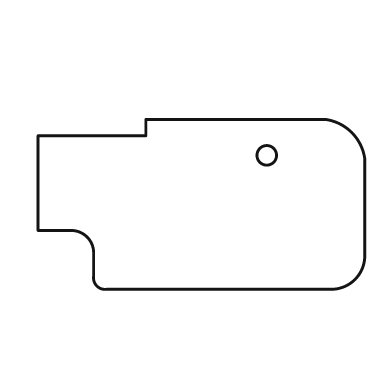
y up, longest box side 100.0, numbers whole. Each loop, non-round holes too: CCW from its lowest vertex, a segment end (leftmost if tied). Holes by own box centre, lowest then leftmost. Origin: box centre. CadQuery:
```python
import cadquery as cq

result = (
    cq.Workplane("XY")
    .moveTo(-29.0, -26.0)
    .lineTo(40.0, -26.0)
    .threePointArc((47.0, -23.0), (50.0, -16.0))
    .lineTo(50.0, 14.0)
    .threePointArc((46.0, 22.0), (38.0, 26.0))
    .lineTo(-17.0, 26.0)
    .lineTo(-17.0, 21.0)
    .lineTo(-50.0, 21.0)
    .lineTo(-50.0, -8.0)
    .lineTo(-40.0, -8.0)
    .threePointArc((-35.0, -10.0), (-33.0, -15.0))
    .lineTo(-33.0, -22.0)
    .threePointArc((-32.0, -25.0), (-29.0, -26.0))
    .close()
    .moveTo(20.0, 15.0)
    .circle(3.0)
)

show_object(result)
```